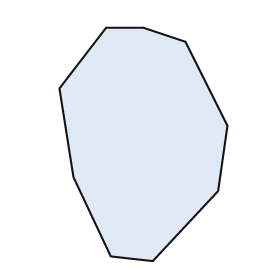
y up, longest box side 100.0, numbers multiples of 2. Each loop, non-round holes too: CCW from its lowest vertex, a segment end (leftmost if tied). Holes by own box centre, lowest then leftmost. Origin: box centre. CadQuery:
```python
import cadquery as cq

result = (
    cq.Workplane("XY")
    .moveTo(4.0, -50.0)
    .lineTo(32.0, -20.0)
    .lineTo(36.0, 8.0)
    .lineTo(18.0, 44.0)
    .lineTo(0.0, 50.0)
    .lineTo(-16.0, 50.0)
    .lineTo(-36.0, 24.0)
    .lineTo(-30.0, -14.0)
    .lineTo(-14.0, -48.0)
    .close()
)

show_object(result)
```